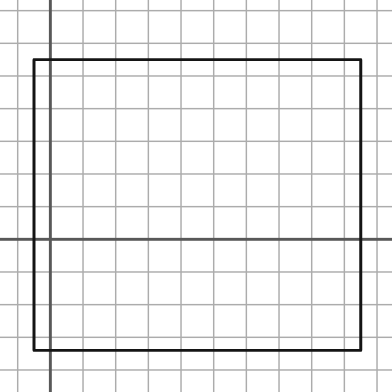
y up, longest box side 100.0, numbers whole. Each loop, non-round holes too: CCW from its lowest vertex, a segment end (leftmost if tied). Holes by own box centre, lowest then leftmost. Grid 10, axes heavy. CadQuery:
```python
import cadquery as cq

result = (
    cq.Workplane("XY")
    .moveTo(-5.0, -34.0)
    .lineTo(95.0, -34.0)
    .lineTo(95.0, 55.0)
    .lineTo(-5.0, 55.0)
    .close()
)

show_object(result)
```